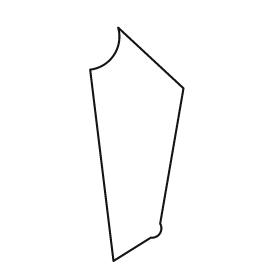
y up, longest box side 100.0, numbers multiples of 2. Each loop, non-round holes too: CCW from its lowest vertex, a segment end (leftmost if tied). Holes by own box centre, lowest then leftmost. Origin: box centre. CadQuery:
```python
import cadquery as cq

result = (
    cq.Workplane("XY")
    .moveTo(-10.0, -50.0)
    .lineTo(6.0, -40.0)
    .threePointArc((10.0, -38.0), (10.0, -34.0))
    .lineTo(20.0, 24.0)
    .lineTo(-8.0, 50.0)
    .threePointArc((-10.0, 38.0), (-20.0, 32.0))
    .close()
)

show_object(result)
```